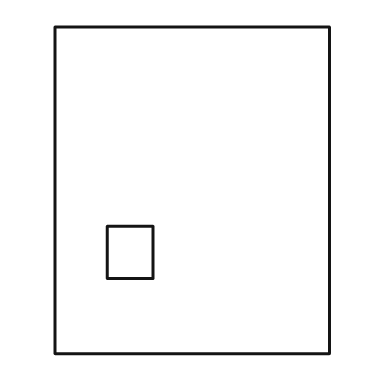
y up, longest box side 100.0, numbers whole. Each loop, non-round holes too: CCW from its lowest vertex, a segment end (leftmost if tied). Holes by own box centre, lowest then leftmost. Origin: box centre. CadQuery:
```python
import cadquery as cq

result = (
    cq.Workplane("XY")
    .moveTo(-42.0, -50.0)
    .lineTo(42.0, -50.0)
    .lineTo(42.0, 50.0)
    .lineTo(-42.0, 50.0)
    .close()
    .moveTo(-26.0, -27.0)
    .lineTo(-12.0, -27.0)
    .lineTo(-12.0, -11.0)
    .lineTo(-26.0, -11.0)
    .close()
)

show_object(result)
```